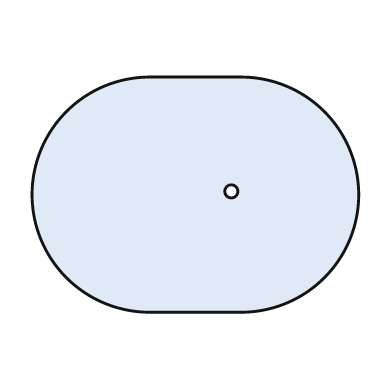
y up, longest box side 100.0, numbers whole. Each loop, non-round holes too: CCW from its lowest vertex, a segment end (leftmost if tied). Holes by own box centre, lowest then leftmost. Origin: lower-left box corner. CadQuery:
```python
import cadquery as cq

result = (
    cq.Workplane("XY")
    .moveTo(36.0, 0.0)
    .lineTo(64.0, 0.0)
    .threePointArc((100.0, 36.0), (64.0, 72.0))
    .lineTo(36.0, 72.0)
    .threePointArc((0.0, 36.0), (36.0, 0.0))
    .close()
    .moveTo(61.0, 37.0)
    .circle(2.0)
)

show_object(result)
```